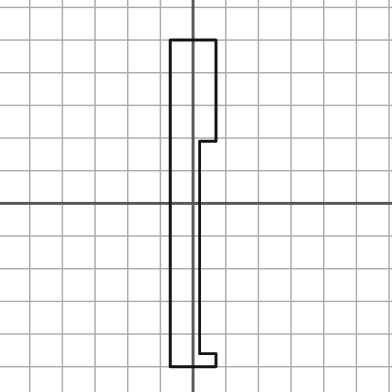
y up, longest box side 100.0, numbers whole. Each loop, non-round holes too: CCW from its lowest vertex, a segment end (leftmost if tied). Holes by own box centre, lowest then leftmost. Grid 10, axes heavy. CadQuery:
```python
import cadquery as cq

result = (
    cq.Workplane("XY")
    .moveTo(-7.0, -50.0)
    .lineTo(7.0, -50.0)
    .lineTo(7.0, -46.0)
    .lineTo(2.0, -46.0)
    .lineTo(2.0, 19.0)
    .lineTo(7.0, 19.0)
    .lineTo(7.0, 50.0)
    .lineTo(-7.0, 50.0)
    .close()
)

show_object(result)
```